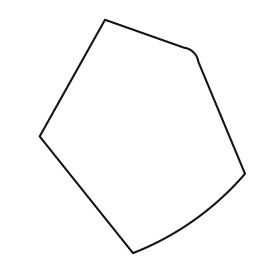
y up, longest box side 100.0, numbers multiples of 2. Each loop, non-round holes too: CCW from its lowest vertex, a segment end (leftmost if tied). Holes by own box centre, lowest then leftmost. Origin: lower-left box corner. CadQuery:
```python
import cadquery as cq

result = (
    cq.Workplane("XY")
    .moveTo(40.0, 0.0)
    .threePointArc((66.0, 14.0), (88.0, 34.0))
    .lineTo(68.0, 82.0)
    .threePointArc((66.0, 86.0), (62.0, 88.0))
    .lineTo(28.0, 100.0)
    .lineTo(0.0, 50.0)
    .close()
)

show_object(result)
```